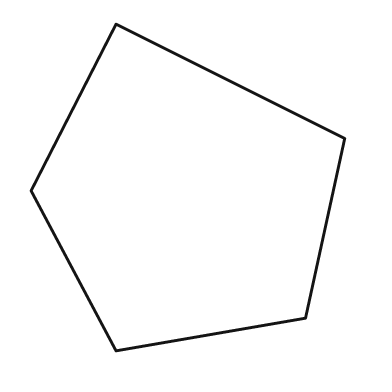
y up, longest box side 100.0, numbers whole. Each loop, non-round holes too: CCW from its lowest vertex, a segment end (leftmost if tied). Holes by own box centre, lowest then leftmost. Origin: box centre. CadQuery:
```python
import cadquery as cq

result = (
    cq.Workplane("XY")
    .moveTo(-22.0, -50.0)
    .lineTo(36.0, -40.0)
    .lineTo(48.0, 15.0)
    .lineTo(-22.0, 50.0)
    .lineTo(-48.0, -1.0)
    .close()
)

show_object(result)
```